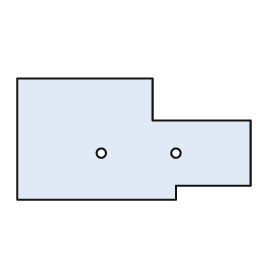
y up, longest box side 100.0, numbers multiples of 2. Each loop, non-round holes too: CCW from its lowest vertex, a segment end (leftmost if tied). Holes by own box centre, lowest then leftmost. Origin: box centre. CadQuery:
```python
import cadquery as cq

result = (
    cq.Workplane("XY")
    .moveTo(-50.0, -26.0)
    .lineTo(18.0, -26.0)
    .lineTo(18.0, -20.0)
    .lineTo(50.0, -20.0)
    .lineTo(50.0, 8.0)
    .lineTo(8.0, 8.0)
    .lineTo(8.0, 26.0)
    .lineTo(-50.0, 26.0)
    .close()
    .moveTo(-14.0, -6.0)
    .circle(2.0)
    .moveTo(18.0, -6.0)
    .circle(2.0)
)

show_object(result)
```